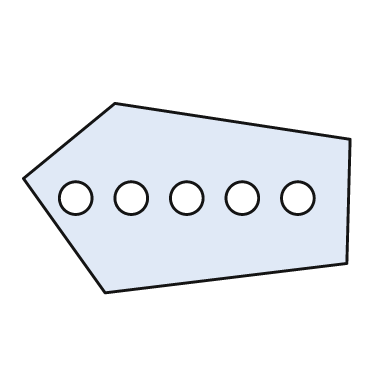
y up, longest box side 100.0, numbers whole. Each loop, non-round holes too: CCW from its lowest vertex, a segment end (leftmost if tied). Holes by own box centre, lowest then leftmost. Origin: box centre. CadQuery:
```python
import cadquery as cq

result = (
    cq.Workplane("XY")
    .moveTo(-25.0, -29.0)
    .lineTo(49.0, -20.0)
    .lineTo(50.0, 18.0)
    .lineTo(-22.0, 29.0)
    .lineTo(-50.0, 6.0)
    .close()
    .moveTo(-34.0, 0.0)
    .circle(5.0)
    .moveTo(-17.0, 0.0)
    .circle(5.0)
    .moveTo(0.0, 0.0)
    .circle(5.0)
    .moveTo(17.0, 0.0)
    .circle(5.0)
    .moveTo(34.0, 0.0)
    .circle(5.0)
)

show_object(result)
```